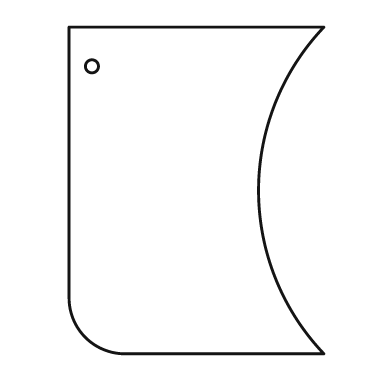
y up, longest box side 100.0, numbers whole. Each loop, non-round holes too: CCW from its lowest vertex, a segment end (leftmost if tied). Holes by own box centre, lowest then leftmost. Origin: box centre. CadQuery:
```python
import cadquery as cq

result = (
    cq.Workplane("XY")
    .moveTo(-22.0, -50.0)
    .lineTo(39.0, -50.0)
    .threePointArc((19.0, 0.0), (39.0, 50.0))
    .lineTo(-39.0, 50.0)
    .lineTo(-39.0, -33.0)
    .threePointArc((-34.0, -45.0), (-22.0, -50.0))
    .close()
    .moveTo(-32.0, 38.0)
    .circle(2.0)
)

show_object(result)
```